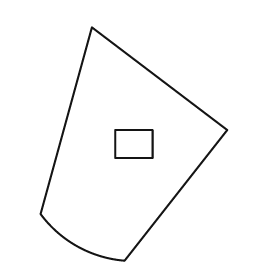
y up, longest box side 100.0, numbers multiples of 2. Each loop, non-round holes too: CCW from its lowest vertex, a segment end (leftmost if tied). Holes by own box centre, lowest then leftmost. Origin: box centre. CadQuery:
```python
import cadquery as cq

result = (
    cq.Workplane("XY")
    .moveTo(-4.0, -50.0)
    .lineTo(40.0, 6.0)
    .lineTo(-18.0, 50.0)
    .lineTo(-40.0, -30.0)
    .threePointArc((-24.0, -44.0), (-4.0, -50.0))
    .close()
    .moveTo(-8.0, -6.0)
    .lineTo(8.0, -6.0)
    .lineTo(8.0, 6.0)
    .lineTo(-8.0, 6.0)
    .close()
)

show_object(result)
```